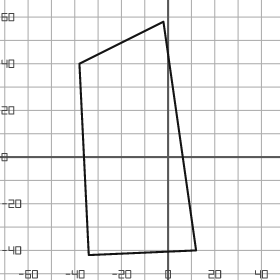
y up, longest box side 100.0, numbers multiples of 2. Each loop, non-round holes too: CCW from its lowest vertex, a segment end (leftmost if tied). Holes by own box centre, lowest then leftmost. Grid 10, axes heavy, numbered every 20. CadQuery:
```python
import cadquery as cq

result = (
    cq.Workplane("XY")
    .moveTo(-34.0, -42.0)
    .lineTo(12.0, -40.0)
    .lineTo(-2.0, 58.0)
    .lineTo(-38.0, 40.0)
    .close()
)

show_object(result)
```